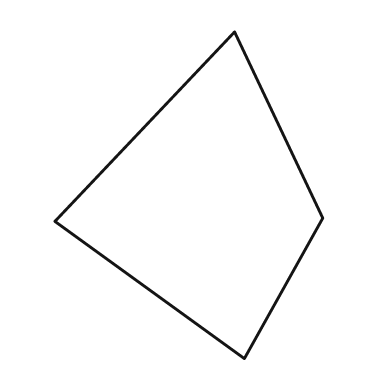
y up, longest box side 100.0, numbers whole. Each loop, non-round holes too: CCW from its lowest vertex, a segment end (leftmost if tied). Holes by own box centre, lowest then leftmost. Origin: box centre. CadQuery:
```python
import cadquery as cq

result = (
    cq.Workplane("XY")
    .moveTo(17.0, -50.0)
    .lineTo(41.0, -7.0)
    .lineTo(14.0, 50.0)
    .lineTo(-41.0, -8.0)
    .close()
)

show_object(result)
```